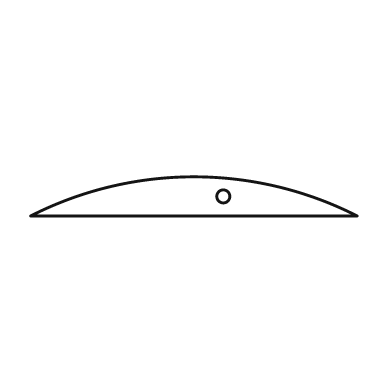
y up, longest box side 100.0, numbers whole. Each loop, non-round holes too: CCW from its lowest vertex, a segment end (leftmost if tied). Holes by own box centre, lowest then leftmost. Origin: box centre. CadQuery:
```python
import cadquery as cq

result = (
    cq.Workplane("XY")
    .moveTo(-50.0, -6.0)
    .lineTo(50.0, -6.0)
    .threePointArc((0.0, 6.0), (-50.0, -6.0))
    .close()
    .moveTo(9.0, 0.0)
    .circle(2.0)
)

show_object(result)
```